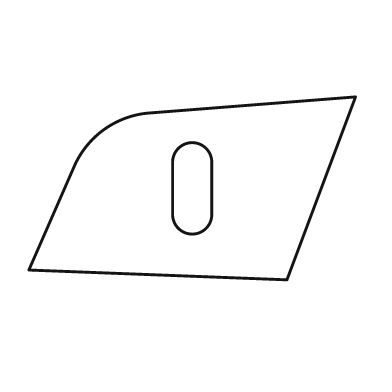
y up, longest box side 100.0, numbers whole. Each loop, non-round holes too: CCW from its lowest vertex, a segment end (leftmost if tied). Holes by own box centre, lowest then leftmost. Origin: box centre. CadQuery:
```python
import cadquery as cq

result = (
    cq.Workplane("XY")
    .moveTo(29.0, -28.0)
    .lineTo(50.0, 28.0)
    .lineTo(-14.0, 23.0)
    .threePointArc((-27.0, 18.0), (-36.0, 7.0))
    .lineTo(-50.0, -25.0)
    .close()
    .moveTo(-6.0, -8.0)
    .threePointArc((0.0, -14.0), (6.0, -8.0))
    .lineTo(6.0, 8.0)
    .threePointArc((0.0, 14.0), (-6.0, 8.0))
    .close()
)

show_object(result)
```